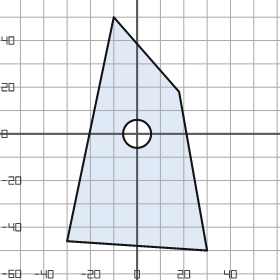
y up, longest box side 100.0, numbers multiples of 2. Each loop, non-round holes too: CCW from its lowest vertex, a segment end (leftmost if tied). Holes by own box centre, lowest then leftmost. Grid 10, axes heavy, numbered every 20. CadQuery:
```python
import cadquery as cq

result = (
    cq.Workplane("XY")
    .moveTo(30.0, -50.0)
    .lineTo(18.0, 18.0)
    .lineTo(-10.0, 50.0)
    .lineTo(-30.0, -46.0)
    .close()
    .moveTo(0.0, 0.0)
    .circle(6.0)
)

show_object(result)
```